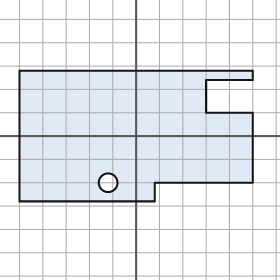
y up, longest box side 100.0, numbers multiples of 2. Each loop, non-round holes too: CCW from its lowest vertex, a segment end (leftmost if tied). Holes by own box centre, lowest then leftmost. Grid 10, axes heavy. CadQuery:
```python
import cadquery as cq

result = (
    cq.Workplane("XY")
    .moveTo(-50.0, -28.0)
    .lineTo(8.0, -28.0)
    .lineTo(8.0, -20.0)
    .lineTo(50.0, -20.0)
    .lineTo(50.0, 10.0)
    .lineTo(30.0, 10.0)
    .lineTo(30.0, 24.0)
    .lineTo(50.0, 24.0)
    .lineTo(50.0, 28.0)
    .lineTo(-50.0, 28.0)
    .close()
    .moveTo(-12.0, -20.0)
    .circle(4.0)
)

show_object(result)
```